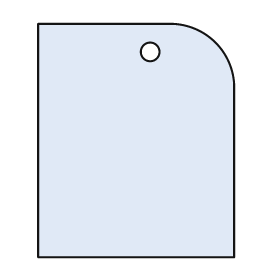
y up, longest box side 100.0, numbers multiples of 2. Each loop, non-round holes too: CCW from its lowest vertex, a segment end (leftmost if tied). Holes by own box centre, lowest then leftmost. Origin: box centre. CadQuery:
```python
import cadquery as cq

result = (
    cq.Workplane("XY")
    .moveTo(-42.0, -50.0)
    .lineTo(42.0, -50.0)
    .lineTo(42.0, 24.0)
    .threePointArc((34.0, 42.0), (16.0, 50.0))
    .lineTo(-42.0, 50.0)
    .close()
    .moveTo(6.0, 38.0)
    .circle(4.0)
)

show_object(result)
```